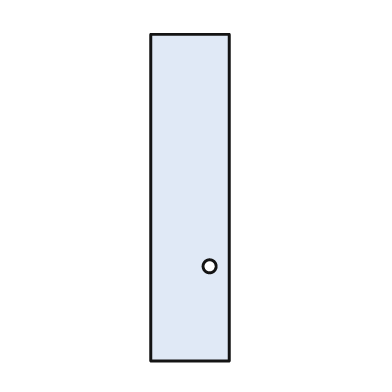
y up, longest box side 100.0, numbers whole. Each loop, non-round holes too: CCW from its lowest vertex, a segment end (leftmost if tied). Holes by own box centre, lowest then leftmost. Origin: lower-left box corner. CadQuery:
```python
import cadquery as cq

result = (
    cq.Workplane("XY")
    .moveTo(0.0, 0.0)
    .lineTo(24.0, 0.0)
    .lineTo(24.0, 100.0)
    .lineTo(0.0, 100.0)
    .close()
    .moveTo(18.0, 29.0)
    .circle(2.0)
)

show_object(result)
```